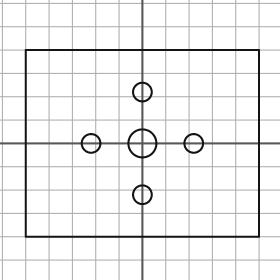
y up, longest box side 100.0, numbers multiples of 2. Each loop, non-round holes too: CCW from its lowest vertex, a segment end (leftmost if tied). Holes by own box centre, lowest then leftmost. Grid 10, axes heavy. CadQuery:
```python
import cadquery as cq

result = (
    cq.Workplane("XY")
    .moveTo(-50.0, -40.0)
    .lineTo(50.0, -40.0)
    .lineTo(50.0, 40.0)
    .lineTo(-50.0, 40.0)
    .close()
    .moveTo(0.0, -22.0)
    .circle(4.0)
    .moveTo(-22.0, 0.0)
    .circle(4.0)
    .moveTo(0.0, 0.0)
    .circle(6.0)
    .moveTo(22.0, 0.0)
    .circle(4.0)
    .moveTo(0.0, 22.0)
    .circle(4.0)
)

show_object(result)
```